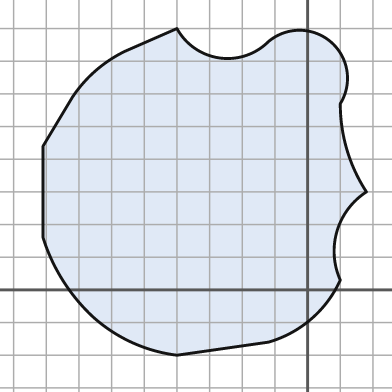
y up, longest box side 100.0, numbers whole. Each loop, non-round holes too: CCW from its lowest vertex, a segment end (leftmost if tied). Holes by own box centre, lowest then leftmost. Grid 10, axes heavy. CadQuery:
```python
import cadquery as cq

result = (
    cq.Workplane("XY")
    .moveTo(-40.0, -20.0)
    .lineTo(-12.0, -16.0)
    .threePointArc((1.0, -9.0), (10.0, 3.0))
    .threePointArc((9.0, 18.0), (18.0, 30.0))
    .threePointArc((12.0, 43.0), (10.0, 57.0))
    .threePointArc((7.0, 76.0), (-12.0, 76.0))
    .threePointArc((-27.0, 71.0), (-40.0, 80.0))
    .lineTo(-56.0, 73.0)
    .threePointArc((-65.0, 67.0), (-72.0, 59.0))
    .lineTo(-81.0, 44.0)
    .lineTo(-81.0, 16.0)
    .threePointArc((-75.0, 3.0), (-66.0, -8.0))
    .threePointArc((-54.0, -16.0), (-40.0, -20.0))
    .close()
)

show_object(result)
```